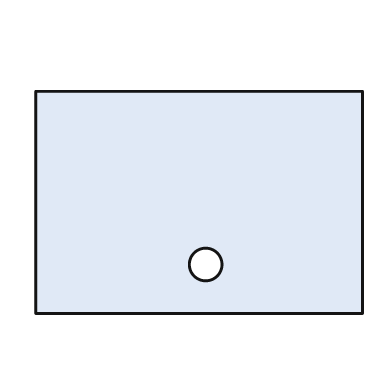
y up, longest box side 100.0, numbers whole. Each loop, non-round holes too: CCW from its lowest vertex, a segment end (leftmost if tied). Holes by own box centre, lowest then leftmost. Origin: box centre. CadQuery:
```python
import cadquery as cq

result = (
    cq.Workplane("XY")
    .moveTo(-50.0, -34.0)
    .lineTo(50.0, -34.0)
    .lineTo(50.0, 34.0)
    .lineTo(-50.0, 34.0)
    .close()
    .moveTo(2.0, -19.0)
    .circle(5.0)
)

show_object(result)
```